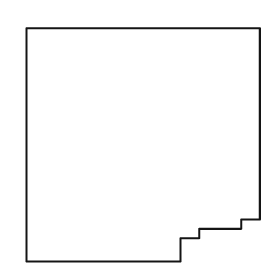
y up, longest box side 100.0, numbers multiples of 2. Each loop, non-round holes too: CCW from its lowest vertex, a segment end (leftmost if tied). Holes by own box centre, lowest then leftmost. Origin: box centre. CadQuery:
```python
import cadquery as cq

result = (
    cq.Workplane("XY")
    .moveTo(-50.0, -50.0)
    .lineTo(16.0, -50.0)
    .lineTo(16.0, -40.0)
    .lineTo(24.0, -40.0)
    .lineTo(24.0, -36.0)
    .lineTo(42.0, -36.0)
    .lineTo(42.0, -32.0)
    .lineTo(50.0, -32.0)
    .lineTo(50.0, 50.0)
    .lineTo(-50.0, 50.0)
    .close()
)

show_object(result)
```